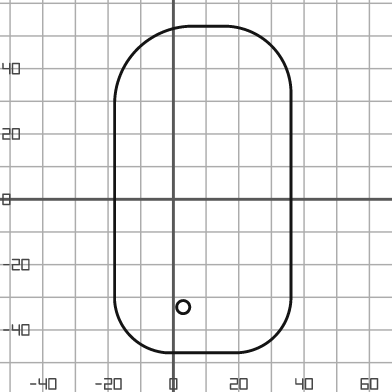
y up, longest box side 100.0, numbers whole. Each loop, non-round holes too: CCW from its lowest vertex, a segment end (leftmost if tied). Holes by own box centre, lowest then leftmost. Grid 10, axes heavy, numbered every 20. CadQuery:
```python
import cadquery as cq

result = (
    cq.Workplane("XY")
    .moveTo(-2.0, -47.0)
    .lineTo(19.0, -47.0)
    .threePointArc((31.0, -42.0), (36.0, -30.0))
    .lineTo(36.0, 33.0)
    .threePointArc((30.0, 47.0), (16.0, 53.0))
    .lineTo(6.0, 53.0)
    .threePointArc((-11.0, 46.0), (-18.0, 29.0))
    .lineTo(-18.0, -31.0)
    .threePointArc((-13.0, -42.0), (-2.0, -47.0))
    .close()
    .moveTo(3.0, -33.0)
    .circle(2.0)
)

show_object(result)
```